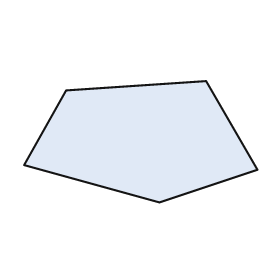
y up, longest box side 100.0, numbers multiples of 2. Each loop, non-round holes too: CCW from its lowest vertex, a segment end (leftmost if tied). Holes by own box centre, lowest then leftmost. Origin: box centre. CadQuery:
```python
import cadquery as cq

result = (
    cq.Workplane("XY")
    .moveTo(8.0, -26.0)
    .lineTo(50.0, -12.0)
    .lineTo(28.0, 26.0)
    .lineTo(-32.0, 22.0)
    .lineTo(-50.0, -10.0)
    .close()
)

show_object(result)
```